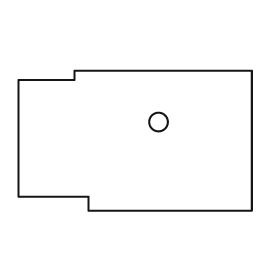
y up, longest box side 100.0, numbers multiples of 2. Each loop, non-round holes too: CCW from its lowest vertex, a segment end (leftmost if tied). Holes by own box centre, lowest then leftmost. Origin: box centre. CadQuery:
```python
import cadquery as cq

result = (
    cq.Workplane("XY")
    .moveTo(-20.0, -30.0)
    .lineTo(50.0, -30.0)
    .lineTo(50.0, 30.0)
    .lineTo(-26.0, 30.0)
    .lineTo(-26.0, 26.0)
    .lineTo(-50.0, 26.0)
    .lineTo(-50.0, -24.0)
    .lineTo(-20.0, -24.0)
    .close()
    .moveTo(10.0, 8.0)
    .circle(4.0)
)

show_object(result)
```